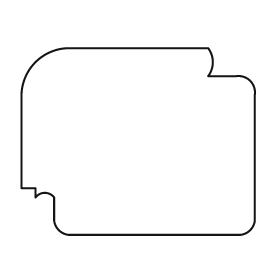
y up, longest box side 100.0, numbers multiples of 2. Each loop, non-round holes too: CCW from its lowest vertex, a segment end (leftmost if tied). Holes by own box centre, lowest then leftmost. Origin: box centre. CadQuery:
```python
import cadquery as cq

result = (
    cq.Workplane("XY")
    .moveTo(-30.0, -40.0)
    .lineTo(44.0, -40.0)
    .threePointArc((48.0, -38.0), (50.0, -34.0))
    .lineTo(50.0, 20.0)
    .threePointArc((48.0, 26.0), (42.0, 28.0))
    .lineTo(30.0, 28.0)
    .threePointArc((32.0, 34.0), (30.0, 40.0))
    .lineTo(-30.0, 40.0)
    .threePointArc((-44.0, 34.0), (-50.0, 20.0))
    .lineTo(-50.0, -20.0)
    .lineTo(-44.0, -20.0)
    .lineTo(-44.0, -24.0)
    .threePointArc((-40.0, -22.0), (-36.0, -24.0))
    .lineTo(-36.0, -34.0)
    .threePointArc((-34.0, -38.0), (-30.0, -40.0))
    .close()
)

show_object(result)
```